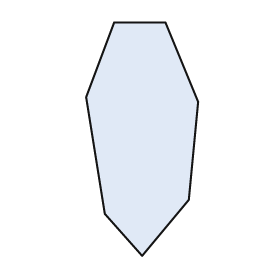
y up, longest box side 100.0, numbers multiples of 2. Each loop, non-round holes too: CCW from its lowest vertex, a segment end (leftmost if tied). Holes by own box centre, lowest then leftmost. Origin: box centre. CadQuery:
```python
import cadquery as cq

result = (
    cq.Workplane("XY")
    .moveTo(0.0, -50.0)
    .lineTo(20.0, -26.0)
    .lineTo(24.0, 16.0)
    .lineTo(10.0, 50.0)
    .lineTo(-12.0, 50.0)
    .lineTo(-24.0, 18.0)
    .lineTo(-16.0, -32.0)
    .close()
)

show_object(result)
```